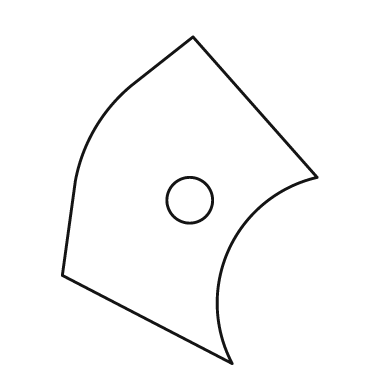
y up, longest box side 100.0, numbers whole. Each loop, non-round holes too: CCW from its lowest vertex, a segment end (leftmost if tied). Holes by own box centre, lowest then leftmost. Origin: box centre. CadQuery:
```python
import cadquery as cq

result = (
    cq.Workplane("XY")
    .moveTo(13.0, -50.0)
    .threePointArc((12.0, -15.0), (39.0, 7.0))
    .lineTo(1.0, 50.0)
    .lineTo(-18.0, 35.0)
    .threePointArc((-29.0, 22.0), (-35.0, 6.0))
    .lineTo(-39.0, -23.0)
    .close()
    .moveTo(0.0, 0.0)
    .circle(7.0)
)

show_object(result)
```